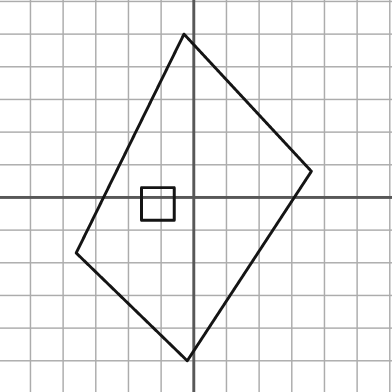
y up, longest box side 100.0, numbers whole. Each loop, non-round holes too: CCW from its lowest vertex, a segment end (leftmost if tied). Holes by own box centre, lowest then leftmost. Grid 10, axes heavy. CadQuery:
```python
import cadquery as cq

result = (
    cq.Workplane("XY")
    .moveTo(-2.0, -50.0)
    .lineTo(36.0, 8.0)
    .lineTo(-3.0, 50.0)
    .lineTo(-36.0, -17.0)
    .close()
    .moveTo(-16.0, -7.0)
    .lineTo(-6.0, -7.0)
    .lineTo(-6.0, 3.0)
    .lineTo(-16.0, 3.0)
    .close()
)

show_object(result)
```